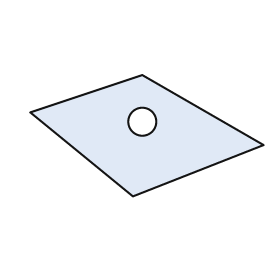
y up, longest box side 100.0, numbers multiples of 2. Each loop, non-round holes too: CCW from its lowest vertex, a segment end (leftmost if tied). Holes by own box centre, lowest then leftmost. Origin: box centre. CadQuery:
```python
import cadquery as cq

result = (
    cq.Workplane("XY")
    .moveTo(-6.0, -26.0)
    .lineTo(50.0, -4.0)
    .lineTo(-2.0, 26.0)
    .lineTo(-50.0, 10.0)
    .close()
    .moveTo(-2.0, 6.0)
    .circle(6.0)
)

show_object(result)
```